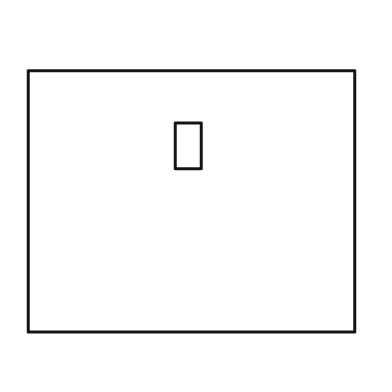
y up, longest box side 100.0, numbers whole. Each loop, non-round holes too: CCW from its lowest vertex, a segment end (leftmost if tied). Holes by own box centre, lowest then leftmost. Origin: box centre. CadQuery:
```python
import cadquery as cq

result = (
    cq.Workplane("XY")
    .moveTo(-50.0, -40.0)
    .lineTo(50.0, -40.0)
    .lineTo(50.0, 40.0)
    .lineTo(-50.0, 40.0)
    .close()
    .moveTo(-5.0, 10.0)
    .lineTo(3.0, 10.0)
    .lineTo(3.0, 24.0)
    .lineTo(-5.0, 24.0)
    .close()
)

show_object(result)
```